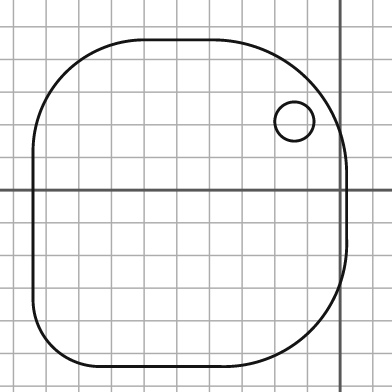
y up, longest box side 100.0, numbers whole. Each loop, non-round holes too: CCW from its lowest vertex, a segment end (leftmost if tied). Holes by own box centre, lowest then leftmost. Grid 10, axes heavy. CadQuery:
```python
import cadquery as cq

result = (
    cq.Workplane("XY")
    .moveTo(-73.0, -54.0)
    .lineTo(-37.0, -54.0)
    .threePointArc((-9.0, -43.0), (2.0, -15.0))
    .lineTo(2.0, 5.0)
    .threePointArc((-10.0, 34.0), (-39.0, 46.0))
    .lineTo(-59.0, 46.0)
    .threePointArc((-84.0, 36.0), (-94.0, 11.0))
    .lineTo(-94.0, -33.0)
    .threePointArc((-88.0, -48.0), (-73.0, -54.0))
    .close()
    .moveTo(-14.0, 21.0)
    .circle(6.0)
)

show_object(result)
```